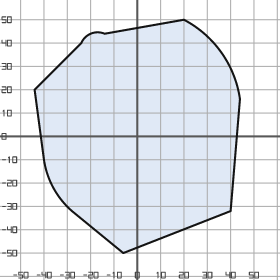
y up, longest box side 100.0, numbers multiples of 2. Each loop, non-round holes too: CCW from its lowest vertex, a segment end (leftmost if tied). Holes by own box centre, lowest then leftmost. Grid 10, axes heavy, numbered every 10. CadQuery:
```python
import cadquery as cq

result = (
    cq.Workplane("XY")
    .moveTo(-6.0, -50.0)
    .lineTo(40.0, -32.0)
    .lineTo(44.0, 16.0)
    .threePointArc((36.0, 36.0), (20.0, 50.0))
    .lineTo(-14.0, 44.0)
    .threePointArc((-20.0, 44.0), (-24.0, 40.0))
    .lineTo(-44.0, 20.0)
    .lineTo(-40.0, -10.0)
    .threePointArc((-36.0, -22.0), (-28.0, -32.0))
    .close()
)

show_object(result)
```